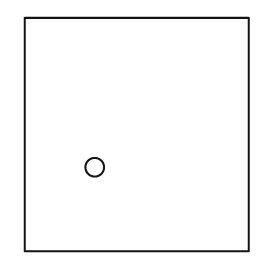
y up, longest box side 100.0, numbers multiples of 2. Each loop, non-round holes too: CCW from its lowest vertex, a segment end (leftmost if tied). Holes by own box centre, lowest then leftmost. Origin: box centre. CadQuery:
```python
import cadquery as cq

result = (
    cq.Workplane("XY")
    .moveTo(-48.0, -50.0)
    .lineTo(48.0, -50.0)
    .lineTo(48.0, 50.0)
    .lineTo(-48.0, 50.0)
    .close()
    .moveTo(-18.0, -14.0)
    .circle(4.0)
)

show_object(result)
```